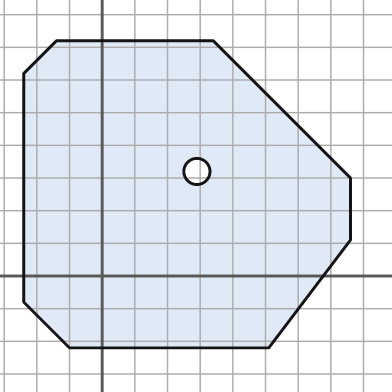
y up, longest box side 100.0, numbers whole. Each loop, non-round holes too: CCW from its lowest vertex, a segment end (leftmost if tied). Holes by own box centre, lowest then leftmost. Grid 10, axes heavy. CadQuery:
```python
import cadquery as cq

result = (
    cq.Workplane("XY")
    .moveTo(-10.0, -22.0)
    .lineTo(51.0, -22.0)
    .lineTo(76.0, 11.0)
    .lineTo(76.0, 30.0)
    .lineTo(34.0, 72.0)
    .lineTo(-14.0, 72.0)
    .lineTo(-24.0, 62.0)
    .lineTo(-24.0, -8.0)
    .close()
    .moveTo(29.0, 32.0)
    .circle(4.0)
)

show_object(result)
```